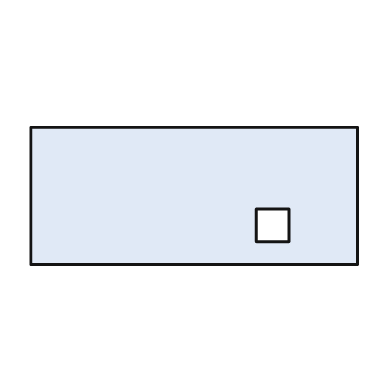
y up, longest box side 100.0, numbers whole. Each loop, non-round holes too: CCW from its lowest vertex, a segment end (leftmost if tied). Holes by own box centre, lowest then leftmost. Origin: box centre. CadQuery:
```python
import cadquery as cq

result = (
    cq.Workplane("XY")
    .moveTo(-50.0, -21.0)
    .lineTo(50.0, -21.0)
    .lineTo(50.0, 21.0)
    .lineTo(-50.0, 21.0)
    .close()
    .moveTo(19.0, -14.0)
    .lineTo(29.0, -14.0)
    .lineTo(29.0, -4.0)
    .lineTo(19.0, -4.0)
    .close()
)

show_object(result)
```